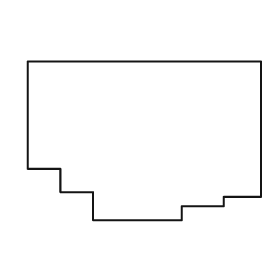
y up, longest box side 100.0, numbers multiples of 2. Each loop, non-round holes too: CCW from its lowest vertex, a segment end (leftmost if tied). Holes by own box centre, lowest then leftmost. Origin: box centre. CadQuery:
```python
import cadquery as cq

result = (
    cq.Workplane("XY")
    .moveTo(-22.0, -34.0)
    .lineTo(16.0, -34.0)
    .lineTo(16.0, -28.0)
    .lineTo(34.0, -28.0)
    .lineTo(34.0, -24.0)
    .lineTo(50.0, -24.0)
    .lineTo(50.0, 34.0)
    .lineTo(-50.0, 34.0)
    .lineTo(-50.0, -12.0)
    .lineTo(-36.0, -12.0)
    .lineTo(-36.0, -22.0)
    .lineTo(-22.0, -22.0)
    .close()
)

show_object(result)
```